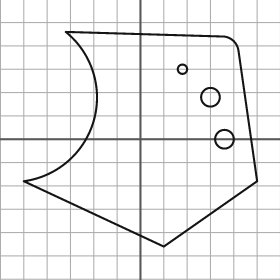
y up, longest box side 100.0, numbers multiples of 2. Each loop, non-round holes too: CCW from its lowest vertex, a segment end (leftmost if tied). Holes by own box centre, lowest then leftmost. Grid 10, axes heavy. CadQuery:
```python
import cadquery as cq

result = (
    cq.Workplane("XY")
    .moveTo(10.0, -46.0)
    .lineTo(50.0, -18.0)
    .lineTo(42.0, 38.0)
    .threePointArc((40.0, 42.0), (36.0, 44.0))
    .lineTo(-32.0, 46.0)
    .threePointArc((-20.0, 8.0), (-50.0, -18.0))
    .close()
    .moveTo(36.0, 0.0)
    .circle(4.0)
    .moveTo(30.0, 18.0)
    .circle(4.0)
    .moveTo(18.0, 30.0)
    .circle(2.0)
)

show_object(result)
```